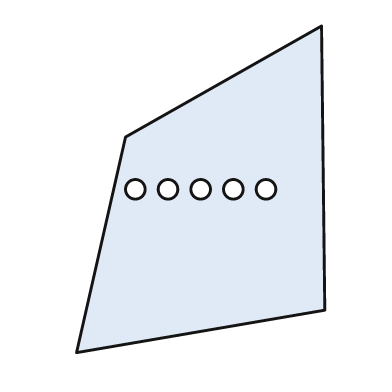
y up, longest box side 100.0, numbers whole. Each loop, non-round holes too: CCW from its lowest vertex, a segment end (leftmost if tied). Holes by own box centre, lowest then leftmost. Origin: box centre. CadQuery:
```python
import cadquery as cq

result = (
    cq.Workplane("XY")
    .moveTo(-38.0, -50.0)
    .lineTo(38.0, -37.0)
    .lineTo(37.0, 50.0)
    .lineTo(-23.0, 16.0)
    .close()
    .moveTo(-20.0, 0.0)
    .circle(3.0)
    .moveTo(-10.0, 0.0)
    .circle(3.0)
    .moveTo(0.0, 0.0)
    .circle(3.0)
    .moveTo(10.0, 0.0)
    .circle(3.0)
    .moveTo(20.0, 0.0)
    .circle(3.0)
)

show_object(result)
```